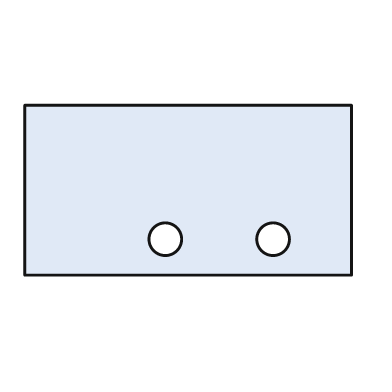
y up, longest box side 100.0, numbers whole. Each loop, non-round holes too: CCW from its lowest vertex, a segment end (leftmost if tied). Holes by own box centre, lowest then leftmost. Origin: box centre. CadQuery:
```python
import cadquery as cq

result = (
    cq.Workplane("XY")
    .moveTo(-50.0, -26.0)
    .lineTo(50.0, -26.0)
    .lineTo(50.0, 26.0)
    .lineTo(-50.0, 26.0)
    .close()
    .moveTo(-7.0, -15.0)
    .circle(5.0)
    .moveTo(26.0, -15.0)
    .circle(5.0)
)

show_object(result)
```